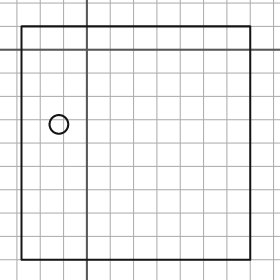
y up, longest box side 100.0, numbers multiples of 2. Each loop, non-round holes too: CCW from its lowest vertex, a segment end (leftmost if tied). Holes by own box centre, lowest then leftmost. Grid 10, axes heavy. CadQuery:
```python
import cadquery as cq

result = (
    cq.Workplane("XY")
    .moveTo(-28.0, -90.0)
    .lineTo(70.0, -90.0)
    .lineTo(70.0, 10.0)
    .lineTo(-28.0, 10.0)
    .close()
    .moveTo(-12.0, -32.0)
    .circle(4.0)
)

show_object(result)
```